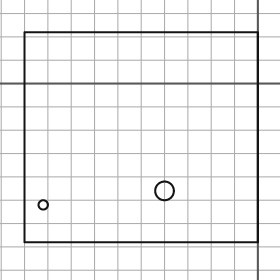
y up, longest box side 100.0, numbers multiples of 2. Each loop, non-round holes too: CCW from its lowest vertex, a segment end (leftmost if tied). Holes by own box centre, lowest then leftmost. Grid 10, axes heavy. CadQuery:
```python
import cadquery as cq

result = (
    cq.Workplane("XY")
    .moveTo(-100.0, -68.0)
    .lineTo(0.0, -68.0)
    .lineTo(0.0, 22.0)
    .lineTo(-100.0, 22.0)
    .close()
    .moveTo(-92.0, -52.0)
    .circle(2.0)
    .moveTo(-40.0, -46.0)
    .circle(4.0)
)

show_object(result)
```